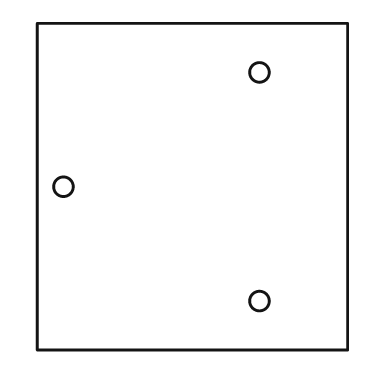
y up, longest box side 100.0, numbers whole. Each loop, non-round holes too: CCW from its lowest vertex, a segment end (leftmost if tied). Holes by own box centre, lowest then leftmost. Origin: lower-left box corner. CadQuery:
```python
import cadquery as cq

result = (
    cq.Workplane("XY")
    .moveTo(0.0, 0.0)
    .lineTo(95.0, 0.0)
    .lineTo(95.0, 100.0)
    .lineTo(0.0, 100.0)
    .close()
    .moveTo(68.0, 15.0)
    .circle(3.0)
    .moveTo(8.0, 50.0)
    .circle(3.0)
    .moveTo(68.0, 85.0)
    .circle(3.0)
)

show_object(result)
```